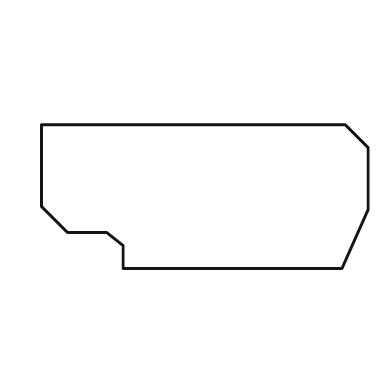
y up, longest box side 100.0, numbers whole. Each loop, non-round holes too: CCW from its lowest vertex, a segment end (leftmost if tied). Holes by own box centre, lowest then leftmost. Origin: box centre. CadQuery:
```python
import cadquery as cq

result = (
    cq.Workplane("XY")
    .moveTo(-25.0, -22.0)
    .lineTo(42.0, -22.0)
    .lineTo(50.0, -4.0)
    .lineTo(50.0, 15.0)
    .lineTo(43.0, 22.0)
    .lineTo(-50.0, 22.0)
    .lineTo(-50.0, -3.0)
    .lineTo(-42.0, -11.0)
    .lineTo(-30.0, -11.0)
    .lineTo(-25.0, -15.0)
    .close()
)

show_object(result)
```